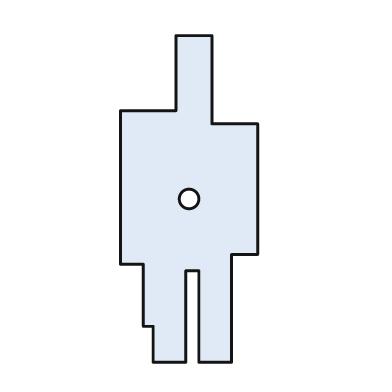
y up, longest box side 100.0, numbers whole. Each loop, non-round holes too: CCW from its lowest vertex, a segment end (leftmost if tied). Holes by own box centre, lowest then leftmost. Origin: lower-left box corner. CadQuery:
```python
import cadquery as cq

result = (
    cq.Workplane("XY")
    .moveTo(10.0, 0.0)
    .lineTo(20.0, 0.0)
    .lineTo(20.0, 28.0)
    .lineTo(24.0, 28.0)
    .lineTo(24.0, 0.0)
    .lineTo(34.0, 0.0)
    .lineTo(34.0, 33.0)
    .lineTo(42.0, 33.0)
    .lineTo(42.0, 73.0)
    .lineTo(28.0, 73.0)
    .lineTo(28.0, 100.0)
    .lineTo(17.0, 100.0)
    .lineTo(17.0, 77.0)
    .lineTo(0.0, 77.0)
    .lineTo(0.0, 30.0)
    .lineTo(7.0, 30.0)
    .lineTo(7.0, 11.0)
    .lineTo(10.0, 11.0)
    .close()
    .moveTo(21.0, 50.0)
    .circle(3.0)
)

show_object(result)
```